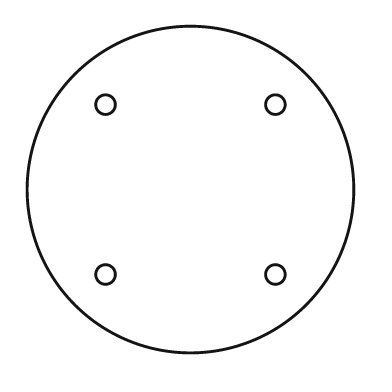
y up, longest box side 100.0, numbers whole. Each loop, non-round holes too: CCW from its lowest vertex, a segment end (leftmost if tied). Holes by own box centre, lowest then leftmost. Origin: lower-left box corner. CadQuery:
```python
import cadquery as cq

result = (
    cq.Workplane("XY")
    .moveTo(50.0, 50.0)
    .circle(50.0)
    .moveTo(24.0, 24.0)
    .circle(3.0)
    .moveTo(76.0, 24.0)
    .circle(3.0)
    .moveTo(24.0, 76.0)
    .circle(3.0)
    .moveTo(76.0, 76.0)
    .circle(3.0)
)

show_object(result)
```